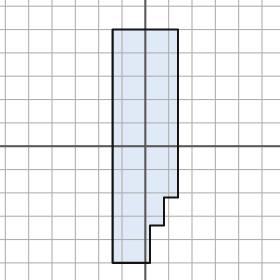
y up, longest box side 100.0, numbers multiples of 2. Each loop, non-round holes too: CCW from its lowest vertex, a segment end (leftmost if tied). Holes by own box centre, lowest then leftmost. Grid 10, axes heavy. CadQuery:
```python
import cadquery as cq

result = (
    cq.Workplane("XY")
    .moveTo(-14.0, -50.0)
    .lineTo(2.0, -50.0)
    .lineTo(2.0, -34.0)
    .lineTo(8.0, -34.0)
    .lineTo(8.0, -22.0)
    .lineTo(14.0, -22.0)
    .lineTo(14.0, 50.0)
    .lineTo(-14.0, 50.0)
    .close()
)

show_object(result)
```